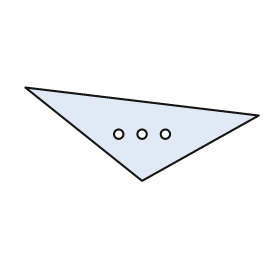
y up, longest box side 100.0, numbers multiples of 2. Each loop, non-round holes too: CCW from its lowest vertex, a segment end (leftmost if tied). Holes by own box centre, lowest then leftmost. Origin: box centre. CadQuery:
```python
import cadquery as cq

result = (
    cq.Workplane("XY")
    .moveTo(0.0, -20.0)
    .lineTo(50.0, 8.0)
    .lineTo(-50.0, 20.0)
    .close()
    .moveTo(-10.0, 0.0)
    .circle(2.0)
    .moveTo(0.0, 0.0)
    .circle(2.0)
    .moveTo(10.0, 0.0)
    .circle(2.0)
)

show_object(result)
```